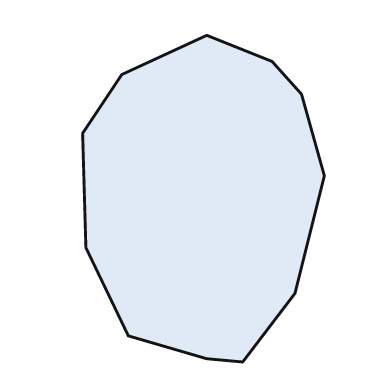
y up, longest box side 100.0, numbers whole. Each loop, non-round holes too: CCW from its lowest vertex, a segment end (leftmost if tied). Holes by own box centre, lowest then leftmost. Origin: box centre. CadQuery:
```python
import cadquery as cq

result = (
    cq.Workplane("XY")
    .moveTo(12.0, -50.0)
    .lineTo(28.0, -29.0)
    .lineTo(37.0, 7.0)
    .lineTo(30.0, 32.0)
    .lineTo(21.0, 42.0)
    .lineTo(1.0, 50.0)
    .lineTo(-25.0, 38.0)
    .lineTo(-37.0, 20.0)
    .lineTo(-36.0, -15.0)
    .lineTo(-23.0, -42.0)
    .lineTo(1.0, -49.0)
    .close()
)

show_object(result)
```